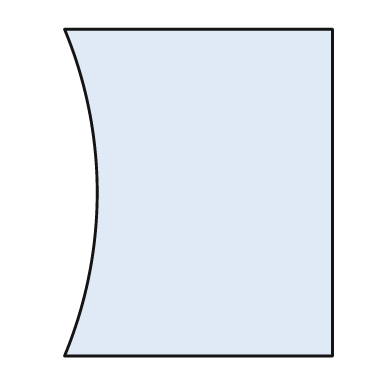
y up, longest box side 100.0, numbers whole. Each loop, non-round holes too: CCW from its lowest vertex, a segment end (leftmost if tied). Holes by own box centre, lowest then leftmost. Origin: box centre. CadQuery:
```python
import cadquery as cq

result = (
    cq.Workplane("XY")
    .moveTo(-41.0, -50.0)
    .lineTo(41.0, -50.0)
    .lineTo(41.0, 50.0)
    .lineTo(-41.0, 50.0)
    .threePointArc((-31.0, 0.0), (-41.0, -50.0))
    .close()
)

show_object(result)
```